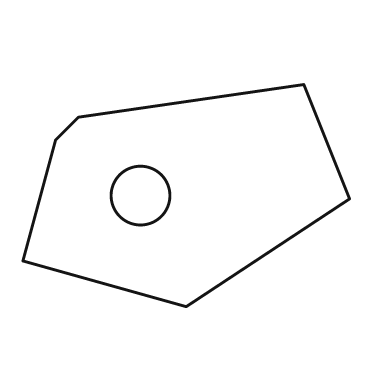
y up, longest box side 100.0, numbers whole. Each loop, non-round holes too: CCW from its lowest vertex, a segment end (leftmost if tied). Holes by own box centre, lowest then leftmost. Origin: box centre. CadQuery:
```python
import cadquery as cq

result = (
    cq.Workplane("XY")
    .moveTo(0.0, -34.0)
    .lineTo(50.0, -1.0)
    .lineTo(36.0, 34.0)
    .lineTo(-33.0, 24.0)
    .lineTo(-40.0, 17.0)
    .lineTo(-50.0, -20.0)
    .close()
    .moveTo(-14.0, 0.0)
    .circle(9.0)
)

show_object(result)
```